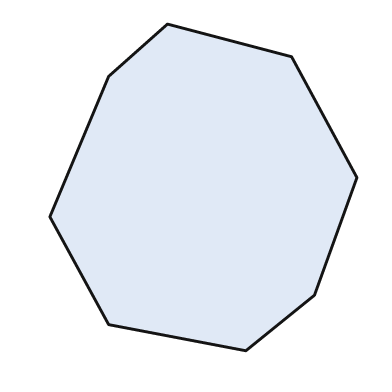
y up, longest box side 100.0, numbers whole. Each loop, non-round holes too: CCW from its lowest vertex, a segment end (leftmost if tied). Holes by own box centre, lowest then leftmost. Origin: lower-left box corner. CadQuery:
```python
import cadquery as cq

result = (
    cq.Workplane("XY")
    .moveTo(60.0, 0.0)
    .lineTo(81.0, 17.0)
    .lineTo(94.0, 53.0)
    .lineTo(74.0, 90.0)
    .lineTo(36.0, 100.0)
    .lineTo(18.0, 84.0)
    .lineTo(0.0, 41.0)
    .lineTo(18.0, 8.0)
    .close()
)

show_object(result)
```